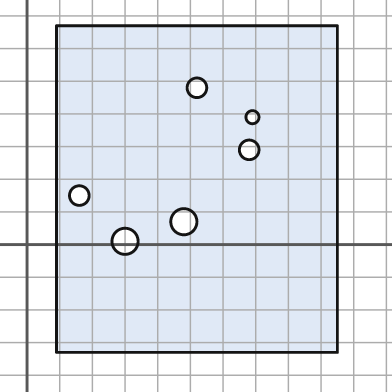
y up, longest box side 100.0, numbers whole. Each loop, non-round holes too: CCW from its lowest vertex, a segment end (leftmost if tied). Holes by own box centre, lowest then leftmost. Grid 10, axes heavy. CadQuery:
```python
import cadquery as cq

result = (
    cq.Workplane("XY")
    .moveTo(9.0, -33.0)
    .lineTo(95.0, -33.0)
    .lineTo(95.0, 67.0)
    .lineTo(9.0, 67.0)
    .close()
    .moveTo(30.0, 1.0)
    .circle(4.0)
    .moveTo(48.0, 7.0)
    .circle(4.0)
    .moveTo(16.0, 15.0)
    .circle(3.0)
    .moveTo(68.0, 29.0)
    .circle(3.0)
    .moveTo(69.0, 39.0)
    .circle(2.0)
    .moveTo(52.0, 48.0)
    .circle(3.0)
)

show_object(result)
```